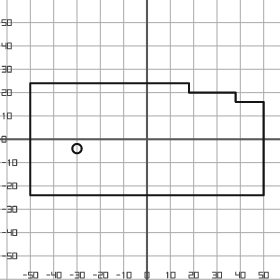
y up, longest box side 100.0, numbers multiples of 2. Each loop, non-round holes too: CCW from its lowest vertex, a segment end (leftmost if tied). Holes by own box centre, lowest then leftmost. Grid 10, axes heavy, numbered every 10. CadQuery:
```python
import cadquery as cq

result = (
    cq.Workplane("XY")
    .moveTo(-50.0, -24.0)
    .lineTo(50.0, -24.0)
    .lineTo(50.0, 16.0)
    .lineTo(38.0, 16.0)
    .lineTo(38.0, 20.0)
    .lineTo(18.0, 20.0)
    .lineTo(18.0, 24.0)
    .lineTo(-50.0, 24.0)
    .close()
    .moveTo(-30.0, -4.0)
    .circle(2.0)
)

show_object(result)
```